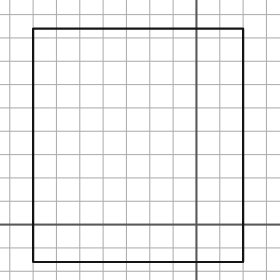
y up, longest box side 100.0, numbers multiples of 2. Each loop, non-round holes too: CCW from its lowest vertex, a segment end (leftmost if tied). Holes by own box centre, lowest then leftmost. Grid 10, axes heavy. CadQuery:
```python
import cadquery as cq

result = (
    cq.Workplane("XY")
    .moveTo(-70.0, -16.0)
    .lineTo(20.0, -16.0)
    .lineTo(20.0, 84.0)
    .lineTo(-70.0, 84.0)
    .close()
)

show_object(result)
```